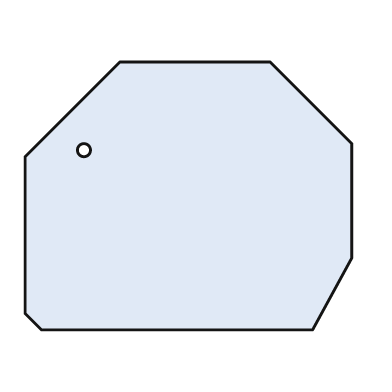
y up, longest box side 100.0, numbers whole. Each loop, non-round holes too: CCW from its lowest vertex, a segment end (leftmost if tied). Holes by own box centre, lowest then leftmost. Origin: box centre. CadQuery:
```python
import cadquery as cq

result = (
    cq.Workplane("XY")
    .moveTo(-45.0, -41.0)
    .lineTo(38.0, -41.0)
    .lineTo(50.0, -19.0)
    .lineTo(50.0, 16.0)
    .lineTo(25.0, 41.0)
    .lineTo(-21.0, 41.0)
    .lineTo(-50.0, 12.0)
    .lineTo(-50.0, -36.0)
    .close()
    .moveTo(-32.0, 14.0)
    .circle(2.0)
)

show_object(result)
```